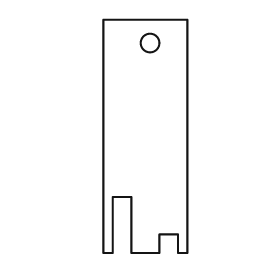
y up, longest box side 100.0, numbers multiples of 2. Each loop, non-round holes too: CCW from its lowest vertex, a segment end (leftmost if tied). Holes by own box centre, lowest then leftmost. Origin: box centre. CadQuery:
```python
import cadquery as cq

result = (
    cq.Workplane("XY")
    .moveTo(-18.0, -50.0)
    .lineTo(-14.0, -50.0)
    .lineTo(-14.0, -26.0)
    .lineTo(-6.0, -26.0)
    .lineTo(-6.0, -50.0)
    .lineTo(6.0, -50.0)
    .lineTo(6.0, -42.0)
    .lineTo(14.0, -42.0)
    .lineTo(14.0, -50.0)
    .lineTo(18.0, -50.0)
    .lineTo(18.0, 50.0)
    .lineTo(-18.0, 50.0)
    .close()
    .moveTo(2.0, 40.0)
    .circle(4.0)
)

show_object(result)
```